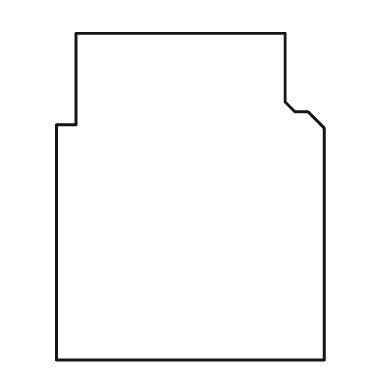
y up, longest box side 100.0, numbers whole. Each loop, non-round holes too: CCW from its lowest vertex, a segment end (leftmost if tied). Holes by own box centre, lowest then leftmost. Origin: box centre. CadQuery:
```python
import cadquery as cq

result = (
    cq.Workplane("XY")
    .moveTo(-41.0, -50.0)
    .lineTo(41.0, -50.0)
    .lineTo(41.0, 21.0)
    .lineTo(36.0, 26.0)
    .lineTo(32.0, 26.0)
    .lineTo(29.0, 29.0)
    .lineTo(29.0, 50.0)
    .lineTo(-35.0, 50.0)
    .lineTo(-35.0, 22.0)
    .lineTo(-41.0, 22.0)
    .close()
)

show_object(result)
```